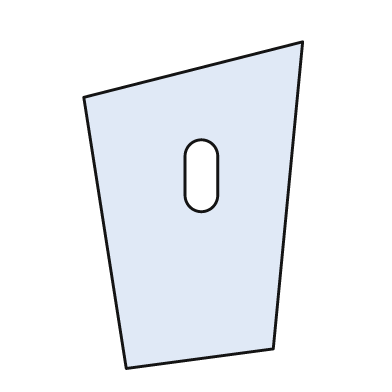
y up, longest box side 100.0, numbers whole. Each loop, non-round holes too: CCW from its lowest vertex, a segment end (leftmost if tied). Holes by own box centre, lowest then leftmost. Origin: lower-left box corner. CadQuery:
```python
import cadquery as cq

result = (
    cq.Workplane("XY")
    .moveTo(13.0, 0.0)
    .lineTo(58.0, 6.0)
    .lineTo(67.0, 100.0)
    .lineTo(0.0, 83.0)
    .close()
    .moveTo(31.0, 53.0)
    .threePointArc((36.0, 48.0), (41.0, 53.0))
    .lineTo(41.0, 65.0)
    .threePointArc((36.0, 70.0), (31.0, 65.0))
    .close()
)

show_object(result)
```